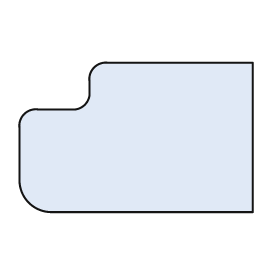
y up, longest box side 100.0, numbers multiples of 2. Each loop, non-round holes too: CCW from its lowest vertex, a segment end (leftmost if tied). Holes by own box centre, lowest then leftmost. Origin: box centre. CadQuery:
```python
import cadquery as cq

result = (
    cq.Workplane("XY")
    .moveTo(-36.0, -32.0)
    .lineTo(50.0, -32.0)
    .lineTo(50.0, 32.0)
    .lineTo(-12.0, 32.0)
    .threePointArc((-18.0, 30.0), (-20.0, 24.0))
    .lineTo(-20.0, 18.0)
    .threePointArc((-22.0, 14.0), (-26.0, 12.0))
    .lineTo(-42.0, 12.0)
    .threePointArc((-48.0, 10.0), (-50.0, 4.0))
    .lineTo(-50.0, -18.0)
    .threePointArc((-46.0, -28.0), (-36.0, -32.0))
    .close()
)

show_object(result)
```